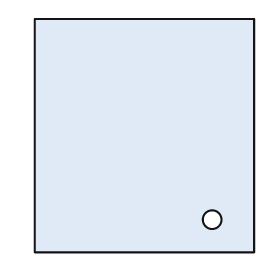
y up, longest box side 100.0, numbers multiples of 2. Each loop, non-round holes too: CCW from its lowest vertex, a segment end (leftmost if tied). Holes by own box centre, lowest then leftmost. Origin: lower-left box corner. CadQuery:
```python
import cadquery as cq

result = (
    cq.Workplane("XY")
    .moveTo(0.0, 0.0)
    .lineTo(94.0, 0.0)
    .lineTo(94.0, 100.0)
    .lineTo(0.0, 100.0)
    .close()
    .moveTo(76.0, 14.0)
    .circle(4.0)
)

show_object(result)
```